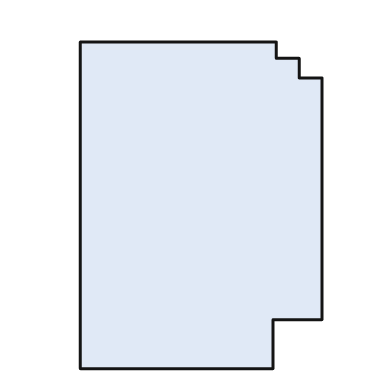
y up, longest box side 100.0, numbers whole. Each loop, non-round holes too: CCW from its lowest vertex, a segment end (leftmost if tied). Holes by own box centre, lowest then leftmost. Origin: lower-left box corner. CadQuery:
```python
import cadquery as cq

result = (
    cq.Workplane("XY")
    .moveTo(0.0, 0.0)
    .lineTo(59.0, 0.0)
    .lineTo(59.0, 15.0)
    .lineTo(74.0, 15.0)
    .lineTo(74.0, 89.0)
    .lineTo(67.0, 89.0)
    .lineTo(67.0, 95.0)
    .lineTo(60.0, 95.0)
    .lineTo(60.0, 100.0)
    .lineTo(0.0, 100.0)
    .close()
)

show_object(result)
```